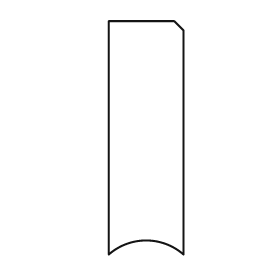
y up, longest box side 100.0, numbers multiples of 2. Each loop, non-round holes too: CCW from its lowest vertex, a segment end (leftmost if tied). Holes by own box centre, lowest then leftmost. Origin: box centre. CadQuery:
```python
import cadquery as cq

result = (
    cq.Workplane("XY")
    .moveTo(-16.0, -50.0)
    .threePointArc((0.0, -44.0), (16.0, -50.0))
    .lineTo(16.0, 46.0)
    .lineTo(12.0, 50.0)
    .lineTo(-16.0, 50.0)
    .close()
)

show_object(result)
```